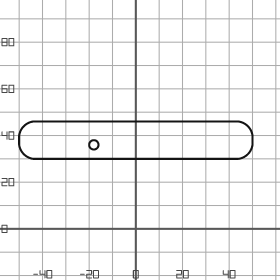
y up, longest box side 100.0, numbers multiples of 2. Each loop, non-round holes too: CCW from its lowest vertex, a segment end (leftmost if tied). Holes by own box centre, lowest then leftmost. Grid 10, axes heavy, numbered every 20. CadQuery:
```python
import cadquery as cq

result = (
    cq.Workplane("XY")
    .moveTo(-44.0, 30.0)
    .lineTo(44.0, 30.0)
    .threePointArc((48.0, 32.0), (50.0, 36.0))
    .lineTo(50.0, 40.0)
    .threePointArc((48.0, 44.0), (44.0, 46.0))
    .lineTo(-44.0, 46.0)
    .threePointArc((-48.0, 44.0), (-50.0, 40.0))
    .lineTo(-50.0, 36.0)
    .threePointArc((-48.0, 32.0), (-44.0, 30.0))
    .close()
    .moveTo(-18.0, 36.0)
    .circle(2.0)
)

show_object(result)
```